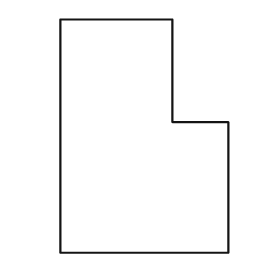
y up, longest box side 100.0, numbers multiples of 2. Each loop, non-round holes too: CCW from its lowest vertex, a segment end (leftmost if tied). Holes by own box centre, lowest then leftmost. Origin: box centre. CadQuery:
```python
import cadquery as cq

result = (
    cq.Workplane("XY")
    .moveTo(-36.0, -50.0)
    .lineTo(36.0, -50.0)
    .lineTo(36.0, 6.0)
    .lineTo(12.0, 6.0)
    .lineTo(12.0, 50.0)
    .lineTo(-36.0, 50.0)
    .close()
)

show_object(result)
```